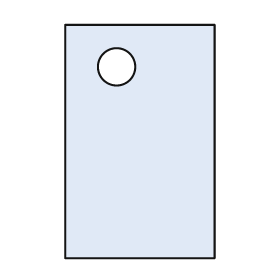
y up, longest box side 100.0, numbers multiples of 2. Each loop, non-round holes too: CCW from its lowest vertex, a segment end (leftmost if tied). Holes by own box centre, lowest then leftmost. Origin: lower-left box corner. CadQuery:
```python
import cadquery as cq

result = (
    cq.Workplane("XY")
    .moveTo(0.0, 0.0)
    .lineTo(64.0, 0.0)
    .lineTo(64.0, 100.0)
    .lineTo(0.0, 100.0)
    .close()
    .moveTo(22.0, 82.0)
    .circle(8.0)
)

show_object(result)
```